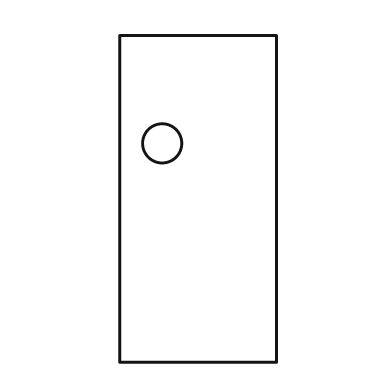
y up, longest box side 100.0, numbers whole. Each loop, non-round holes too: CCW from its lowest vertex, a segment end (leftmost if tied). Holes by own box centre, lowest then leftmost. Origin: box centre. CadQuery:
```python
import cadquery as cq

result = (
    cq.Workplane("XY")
    .moveTo(-24.0, -50.0)
    .lineTo(24.0, -50.0)
    .lineTo(24.0, 50.0)
    .lineTo(-24.0, 50.0)
    .close()
    .moveTo(-11.0, 17.0)
    .circle(6.0)
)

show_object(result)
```